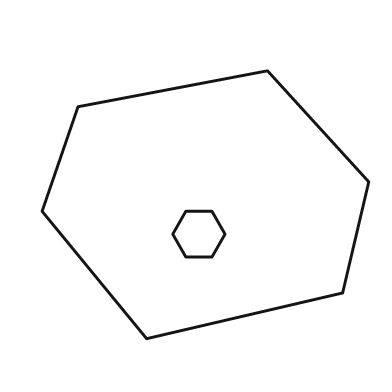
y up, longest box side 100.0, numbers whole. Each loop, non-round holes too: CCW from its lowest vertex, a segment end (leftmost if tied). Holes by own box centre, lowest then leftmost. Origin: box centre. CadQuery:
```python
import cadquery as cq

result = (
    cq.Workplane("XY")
    .moveTo(-18.0, -41.0)
    .lineTo(42.0, -27.0)
    .lineTo(50.0, 7.0)
    .lineTo(19.0, 41.0)
    .lineTo(-39.0, 30.0)
    .lineTo(-50.0, -2.0)
    .close()
    .moveTo(-6.0, -16.0)
    .lineTo(2.0, -16.0)
    .lineTo(6.0, -9.0)
    .lineTo(2.0, -2.0)
    .lineTo(-6.0, -2.0)
    .lineTo(-10.0, -9.0)
    .close()
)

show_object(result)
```